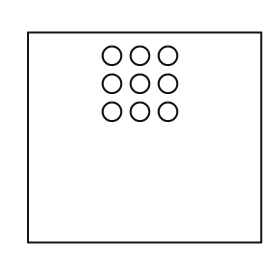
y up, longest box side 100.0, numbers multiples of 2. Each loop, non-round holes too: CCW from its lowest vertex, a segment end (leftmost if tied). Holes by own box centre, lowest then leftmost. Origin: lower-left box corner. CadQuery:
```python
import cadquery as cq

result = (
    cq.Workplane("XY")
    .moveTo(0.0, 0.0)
    .lineTo(100.0, 0.0)
    .lineTo(100.0, 90.0)
    .lineTo(0.0, 90.0)
    .close()
    .moveTo(36.0, 56.0)
    .circle(4.0)
    .moveTo(48.0, 56.0)
    .circle(4.0)
    .moveTo(60.0, 56.0)
    .circle(4.0)
    .moveTo(36.0, 68.0)
    .circle(4.0)
    .moveTo(48.0, 68.0)
    .circle(4.0)
    .moveTo(60.0, 68.0)
    .circle(4.0)
    .moveTo(36.0, 80.0)
    .circle(4.0)
    .moveTo(48.0, 80.0)
    .circle(4.0)
    .moveTo(60.0, 80.0)
    .circle(4.0)
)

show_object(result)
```